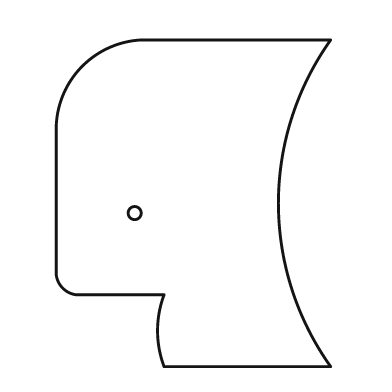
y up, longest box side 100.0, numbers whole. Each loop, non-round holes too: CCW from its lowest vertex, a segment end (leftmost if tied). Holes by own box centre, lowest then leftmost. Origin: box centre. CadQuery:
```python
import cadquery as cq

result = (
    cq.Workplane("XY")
    .moveTo(-9.0, -50.0)
    .lineTo(42.0, -50.0)
    .threePointArc((26.0, 0.0), (42.0, 50.0))
    .lineTo(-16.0, 50.0)
    .threePointArc((-34.0, 42.0), (-42.0, 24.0))
    .lineTo(-42.0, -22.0)
    .threePointArc((-40.0, -26.0), (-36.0, -28.0))
    .lineTo(-9.0, -28.0)
    .threePointArc((-11.0, -39.0), (-9.0, -50.0))
    .close()
    .moveTo(-18.0, -3.0)
    .circle(2.0)
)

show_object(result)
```